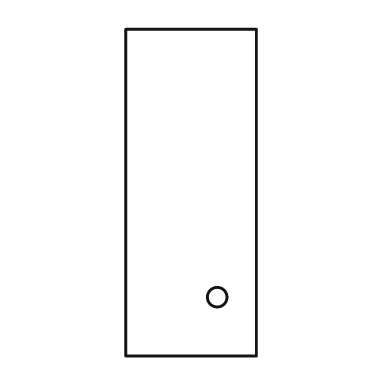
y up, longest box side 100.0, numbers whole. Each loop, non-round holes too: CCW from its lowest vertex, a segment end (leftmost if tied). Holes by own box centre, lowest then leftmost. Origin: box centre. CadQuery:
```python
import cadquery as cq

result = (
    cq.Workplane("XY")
    .moveTo(-20.0, -50.0)
    .lineTo(20.0, -50.0)
    .lineTo(20.0, 50.0)
    .lineTo(-20.0, 50.0)
    .close()
    .moveTo(8.0, -32.0)
    .circle(3.0)
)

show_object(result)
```